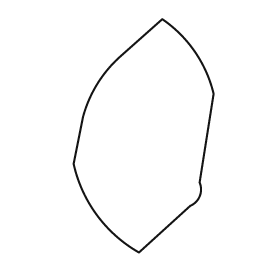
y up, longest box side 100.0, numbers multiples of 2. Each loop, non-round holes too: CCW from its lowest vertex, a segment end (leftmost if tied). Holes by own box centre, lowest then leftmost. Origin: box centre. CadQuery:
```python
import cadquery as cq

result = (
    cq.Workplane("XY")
    .moveTo(-2.0, -50.0)
    .lineTo(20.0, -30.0)
    .threePointArc((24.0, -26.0), (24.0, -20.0))
    .lineTo(30.0, 18.0)
    .threePointArc((22.0, 36.0), (8.0, 50.0))
    .lineTo(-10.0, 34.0)
    .threePointArc((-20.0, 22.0), (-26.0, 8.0))
    .lineTo(-30.0, -12.0)
    .threePointArc((-20.0, -34.0), (-2.0, -50.0))
    .close()
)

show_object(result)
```